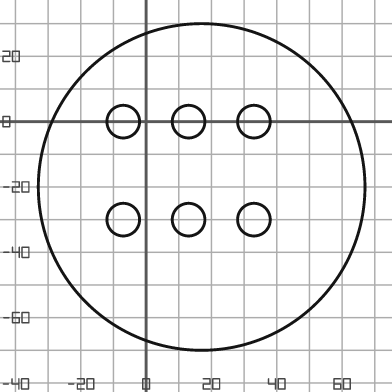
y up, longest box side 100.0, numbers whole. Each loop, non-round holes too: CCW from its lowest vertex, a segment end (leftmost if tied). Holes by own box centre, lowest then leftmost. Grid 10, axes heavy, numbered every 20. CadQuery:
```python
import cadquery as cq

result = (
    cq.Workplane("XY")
    .moveTo(17.0, -20.0)
    .circle(50.0)
    .moveTo(-7.0, -30.0)
    .circle(5.0)
    .moveTo(13.0, -30.0)
    .circle(5.0)
    .moveTo(33.0, -30.0)
    .circle(5.0)
    .moveTo(-7.0, 0.0)
    .circle(5.0)
    .moveTo(13.0, 0.0)
    .circle(5.0)
    .moveTo(33.0, 0.0)
    .circle(5.0)
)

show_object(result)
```